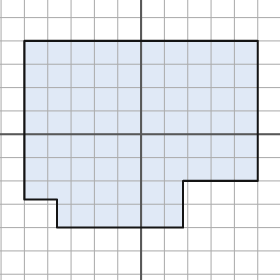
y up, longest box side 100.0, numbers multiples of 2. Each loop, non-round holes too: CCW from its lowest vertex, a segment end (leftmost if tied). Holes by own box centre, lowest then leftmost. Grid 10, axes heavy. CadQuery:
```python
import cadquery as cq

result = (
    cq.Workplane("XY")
    .moveTo(-36.0, -40.0)
    .lineTo(18.0, -40.0)
    .lineTo(18.0, -20.0)
    .lineTo(50.0, -20.0)
    .lineTo(50.0, 40.0)
    .lineTo(-50.0, 40.0)
    .lineTo(-50.0, -28.0)
    .lineTo(-36.0, -28.0)
    .close()
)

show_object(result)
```